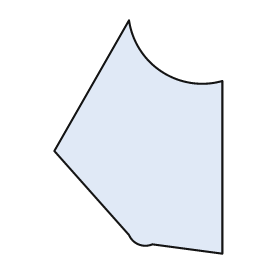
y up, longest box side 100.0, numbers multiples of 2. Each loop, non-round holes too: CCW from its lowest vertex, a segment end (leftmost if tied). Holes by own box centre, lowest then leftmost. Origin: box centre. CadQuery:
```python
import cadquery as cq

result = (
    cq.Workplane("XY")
    .moveTo(36.0, -50.0)
    .lineTo(36.0, 24.0)
    .threePointArc((10.0, 28.0), (-4.0, 50.0))
    .lineTo(-36.0, -6.0)
    .lineTo(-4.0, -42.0)
    .threePointArc((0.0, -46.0), (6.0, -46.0))
    .close()
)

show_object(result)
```